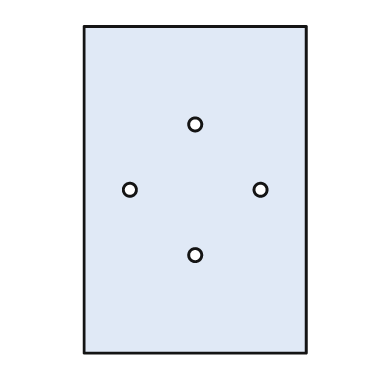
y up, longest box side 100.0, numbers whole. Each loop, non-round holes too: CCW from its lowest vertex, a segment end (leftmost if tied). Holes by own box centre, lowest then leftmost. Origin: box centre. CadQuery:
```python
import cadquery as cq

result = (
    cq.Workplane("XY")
    .moveTo(-34.0, -50.0)
    .lineTo(34.0, -50.0)
    .lineTo(34.0, 50.0)
    .lineTo(-34.0, 50.0)
    .close()
    .moveTo(0.0, -20.0)
    .circle(2.0)
    .moveTo(-20.0, 0.0)
    .circle(2.0)
    .moveTo(20.0, 0.0)
    .circle(2.0)
    .moveTo(0.0, 20.0)
    .circle(2.0)
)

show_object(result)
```